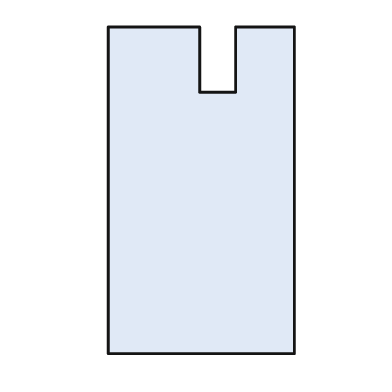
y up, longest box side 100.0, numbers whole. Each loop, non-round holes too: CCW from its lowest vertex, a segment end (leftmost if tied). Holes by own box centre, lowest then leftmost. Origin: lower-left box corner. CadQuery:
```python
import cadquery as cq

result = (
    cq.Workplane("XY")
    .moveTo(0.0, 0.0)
    .lineTo(57.0, 0.0)
    .lineTo(57.0, 100.0)
    .lineTo(39.0, 100.0)
    .lineTo(39.0, 80.0)
    .lineTo(28.0, 80.0)
    .lineTo(28.0, 100.0)
    .lineTo(0.0, 100.0)
    .close()
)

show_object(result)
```